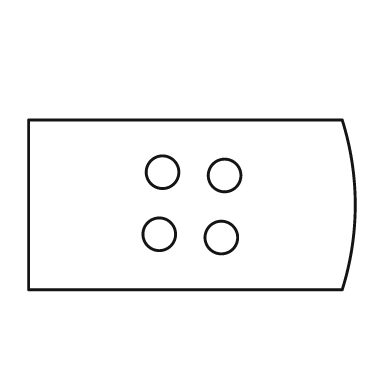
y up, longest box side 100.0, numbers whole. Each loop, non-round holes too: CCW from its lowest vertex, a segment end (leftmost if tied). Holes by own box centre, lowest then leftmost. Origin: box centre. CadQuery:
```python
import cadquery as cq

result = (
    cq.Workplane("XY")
    .moveTo(-50.0, -26.0)
    .lineTo(46.0, -26.0)
    .threePointArc((50.0, 0.0), (46.0, 26.0))
    .lineTo(-50.0, 26.0)
    .close()
    .moveTo(9.0, -10.0)
    .circle(5.0)
    .moveTo(-10.0, -9.0)
    .circle(5.0)
    .moveTo(10.0, 9.0)
    .circle(5.0)
    .moveTo(-9.0, 10.0)
    .circle(5.0)
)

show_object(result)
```